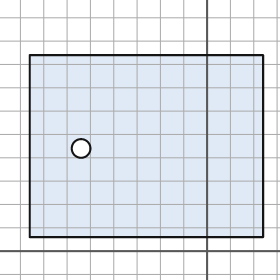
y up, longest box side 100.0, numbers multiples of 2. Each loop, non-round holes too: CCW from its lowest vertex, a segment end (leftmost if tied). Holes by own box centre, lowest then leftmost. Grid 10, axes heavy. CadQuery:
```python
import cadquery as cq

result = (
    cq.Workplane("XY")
    .moveTo(-76.0, 6.0)
    .lineTo(24.0, 6.0)
    .lineTo(24.0, 84.0)
    .lineTo(-76.0, 84.0)
    .close()
    .moveTo(-54.0, 44.0)
    .circle(4.0)
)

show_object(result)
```